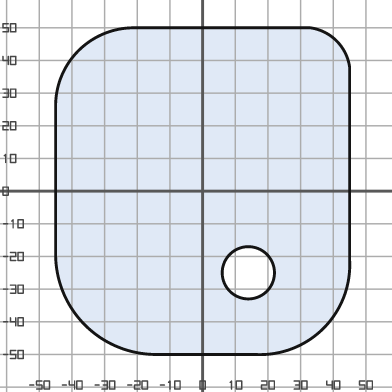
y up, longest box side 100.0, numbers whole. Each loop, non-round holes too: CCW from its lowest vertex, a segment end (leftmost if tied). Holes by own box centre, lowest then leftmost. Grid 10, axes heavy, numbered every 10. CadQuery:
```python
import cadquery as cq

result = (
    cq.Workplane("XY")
    .moveTo(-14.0, -50.0)
    .lineTo(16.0, -50.0)
    .threePointArc((37.0, -42.0), (45.0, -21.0))
    .lineTo(45.0, 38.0)
    .threePointArc((41.0, 46.0), (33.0, 50.0))
    .lineTo(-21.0, 50.0)
    .threePointArc((-38.0, 43.0), (-45.0, 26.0))
    .lineTo(-45.0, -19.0)
    .threePointArc((-36.0, -41.0), (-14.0, -50.0))
    .close()
    .moveTo(14.0, -25.0)
    .circle(8.0)
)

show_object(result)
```